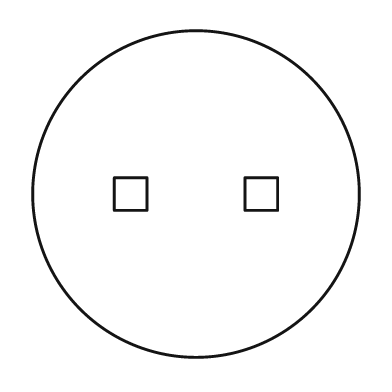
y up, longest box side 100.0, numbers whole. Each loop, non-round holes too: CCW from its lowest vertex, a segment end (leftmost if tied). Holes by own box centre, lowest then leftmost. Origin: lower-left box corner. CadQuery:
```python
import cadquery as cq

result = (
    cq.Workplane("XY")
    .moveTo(50.0, 50.0)
    .circle(50.0)
    .moveTo(25.0, 45.0)
    .lineTo(35.0, 45.0)
    .lineTo(35.0, 55.0)
    .lineTo(25.0, 55.0)
    .close()
    .moveTo(65.0, 45.0)
    .lineTo(75.0, 45.0)
    .lineTo(75.0, 55.0)
    .lineTo(65.0, 55.0)
    .close()
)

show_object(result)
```